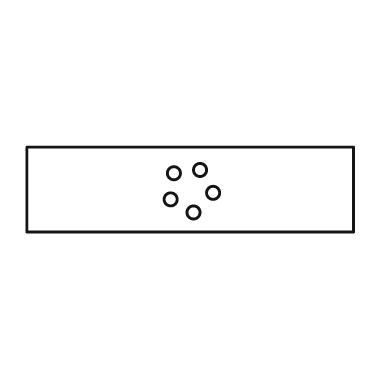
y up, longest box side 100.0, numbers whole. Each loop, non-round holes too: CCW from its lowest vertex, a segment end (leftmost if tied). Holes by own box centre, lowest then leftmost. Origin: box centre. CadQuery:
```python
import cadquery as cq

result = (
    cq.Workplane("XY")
    .moveTo(-50.0, -13.0)
    .lineTo(50.0, -13.0)
    .lineTo(50.0, 13.0)
    .lineTo(-50.0, 13.0)
    .close()
    .moveTo(1.0, -7.0)
    .circle(2.0)
    .moveTo(-6.0, -3.0)
    .circle(2.0)
    .moveTo(7.0, -1.0)
    .circle(2.0)
    .moveTo(-5.0, 5.0)
    .circle(2.0)
    .moveTo(3.0, 6.0)
    .circle(2.0)
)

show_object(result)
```